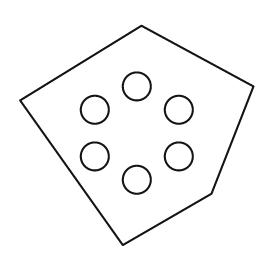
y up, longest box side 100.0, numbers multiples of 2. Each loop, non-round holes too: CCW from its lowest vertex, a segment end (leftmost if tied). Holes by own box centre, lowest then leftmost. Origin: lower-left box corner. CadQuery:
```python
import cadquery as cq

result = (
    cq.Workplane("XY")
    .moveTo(44.0, 0.0)
    .lineTo(82.0, 22.0)
    .lineTo(100.0, 68.0)
    .lineTo(52.0, 94.0)
    .lineTo(0.0, 62.0)
    .close()
    .moveTo(50.0, 28.0)
    .circle(6.0)
    .moveTo(32.0, 38.0)
    .circle(6.0)
    .moveTo(68.0, 38.0)
    .circle(6.0)
    .moveTo(32.0, 58.0)
    .circle(6.0)
    .moveTo(68.0, 58.0)
    .circle(6.0)
    .moveTo(50.0, 68.0)
    .circle(6.0)
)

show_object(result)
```